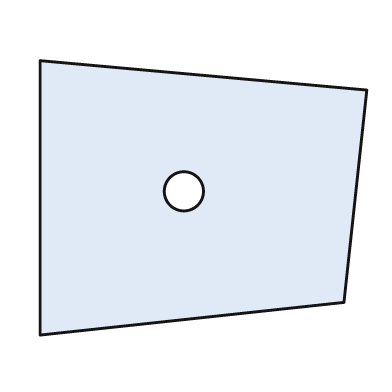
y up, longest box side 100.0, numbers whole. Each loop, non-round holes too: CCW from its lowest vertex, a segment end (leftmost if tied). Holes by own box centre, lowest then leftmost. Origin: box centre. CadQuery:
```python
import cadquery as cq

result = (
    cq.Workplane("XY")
    .moveTo(-50.0, -42.0)
    .lineTo(43.0, -32.0)
    .lineTo(50.0, 33.0)
    .lineTo(-50.0, 42.0)
    .close()
    .moveTo(-6.0, 2.0)
    .circle(6.0)
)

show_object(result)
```